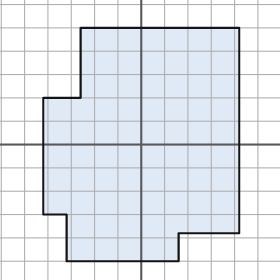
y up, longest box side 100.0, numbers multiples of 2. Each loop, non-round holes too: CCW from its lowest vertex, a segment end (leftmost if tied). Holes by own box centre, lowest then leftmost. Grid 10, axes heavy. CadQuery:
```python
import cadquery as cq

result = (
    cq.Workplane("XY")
    .moveTo(-32.0, -50.0)
    .lineTo(16.0, -50.0)
    .lineTo(16.0, -38.0)
    .lineTo(42.0, -38.0)
    .lineTo(42.0, 50.0)
    .lineTo(-26.0, 50.0)
    .lineTo(-26.0, 20.0)
    .lineTo(-42.0, 20.0)
    .lineTo(-42.0, -30.0)
    .lineTo(-32.0, -30.0)
    .close()
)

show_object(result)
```